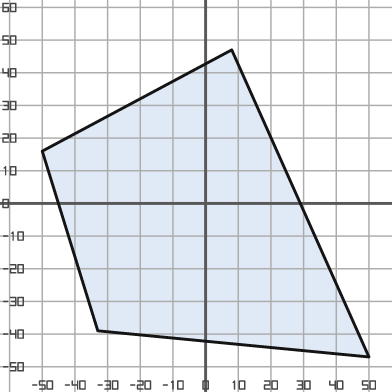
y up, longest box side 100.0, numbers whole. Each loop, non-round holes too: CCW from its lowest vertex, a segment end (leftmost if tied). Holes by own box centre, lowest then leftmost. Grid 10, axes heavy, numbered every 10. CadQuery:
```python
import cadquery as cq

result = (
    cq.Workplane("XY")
    .moveTo(50.0, -47.0)
    .lineTo(8.0, 47.0)
    .lineTo(-50.0, 16.0)
    .lineTo(-33.0, -39.0)
    .close()
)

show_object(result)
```